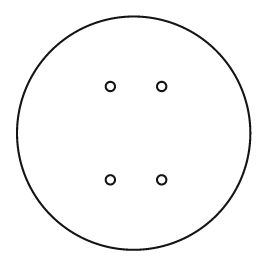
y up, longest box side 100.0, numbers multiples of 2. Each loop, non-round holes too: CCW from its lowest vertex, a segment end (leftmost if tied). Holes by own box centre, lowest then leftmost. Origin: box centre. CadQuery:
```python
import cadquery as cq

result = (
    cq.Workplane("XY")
    .moveTo(0.0, 0.0)
    .circle(50.0)
    .moveTo(-10.0, -20.0)
    .circle(2.0)
    .moveTo(12.0, -20.0)
    .circle(2.0)
    .moveTo(-10.0, 20.0)
    .circle(2.0)
    .moveTo(12.0, 20.0)
    .circle(2.0)
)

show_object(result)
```